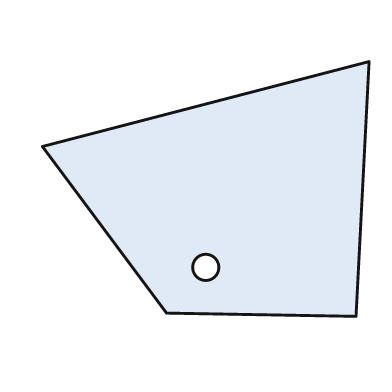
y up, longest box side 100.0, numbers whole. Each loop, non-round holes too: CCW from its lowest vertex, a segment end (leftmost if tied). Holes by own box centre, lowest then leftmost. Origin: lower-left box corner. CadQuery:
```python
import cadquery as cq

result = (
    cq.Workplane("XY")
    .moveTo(96.0, 0.0)
    .lineTo(100.0, 78.0)
    .lineTo(0.0, 52.0)
    .lineTo(38.0, 1.0)
    .close()
    .moveTo(50.0, 15.0)
    .circle(4.0)
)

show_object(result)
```